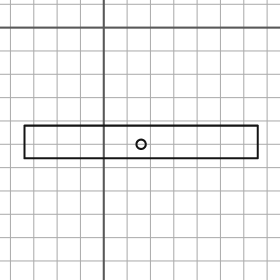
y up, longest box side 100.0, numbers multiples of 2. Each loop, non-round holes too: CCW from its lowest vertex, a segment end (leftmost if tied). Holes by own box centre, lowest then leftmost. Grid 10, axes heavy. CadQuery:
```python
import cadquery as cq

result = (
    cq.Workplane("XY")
    .moveTo(-34.0, -56.0)
    .lineTo(66.0, -56.0)
    .lineTo(66.0, -42.0)
    .lineTo(-34.0, -42.0)
    .close()
    .moveTo(16.0, -50.0)
    .circle(2.0)
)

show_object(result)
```